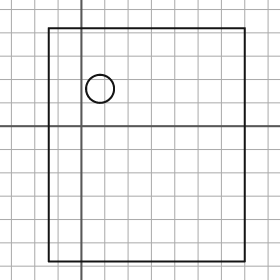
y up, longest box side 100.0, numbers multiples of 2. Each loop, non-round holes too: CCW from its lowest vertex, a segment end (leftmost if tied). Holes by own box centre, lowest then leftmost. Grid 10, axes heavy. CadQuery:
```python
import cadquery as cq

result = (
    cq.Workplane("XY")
    .moveTo(-14.0, -58.0)
    .lineTo(70.0, -58.0)
    .lineTo(70.0, 42.0)
    .lineTo(-14.0, 42.0)
    .close()
    .moveTo(8.0, 16.0)
    .circle(6.0)
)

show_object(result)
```